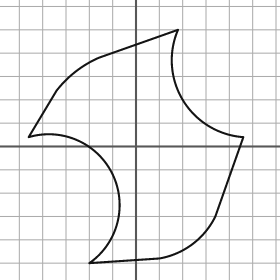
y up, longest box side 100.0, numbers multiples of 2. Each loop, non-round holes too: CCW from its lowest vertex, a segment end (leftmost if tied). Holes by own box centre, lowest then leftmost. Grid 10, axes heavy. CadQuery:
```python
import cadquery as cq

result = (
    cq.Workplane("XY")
    .moveTo(-20.0, -50.0)
    .lineTo(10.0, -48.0)
    .threePointArc((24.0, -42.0), (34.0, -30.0))
    .lineTo(46.0, 4.0)
    .threePointArc((20.0, 20.0), (18.0, 50.0))
    .lineTo(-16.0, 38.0)
    .threePointArc((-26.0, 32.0), (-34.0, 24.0))
    .lineTo(-46.0, 4.0)
    .threePointArc((-10.0, -12.0), (-20.0, -50.0))
    .close()
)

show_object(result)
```